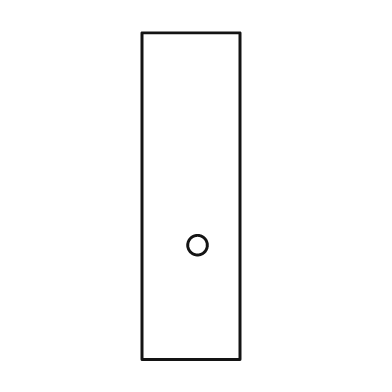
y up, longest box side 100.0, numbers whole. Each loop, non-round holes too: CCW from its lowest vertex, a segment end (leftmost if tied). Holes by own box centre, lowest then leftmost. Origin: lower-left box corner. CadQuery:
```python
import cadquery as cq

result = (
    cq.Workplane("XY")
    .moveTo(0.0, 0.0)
    .lineTo(30.0, 0.0)
    .lineTo(30.0, 100.0)
    .lineTo(0.0, 100.0)
    .close()
    .moveTo(17.0, 35.0)
    .circle(3.0)
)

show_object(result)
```